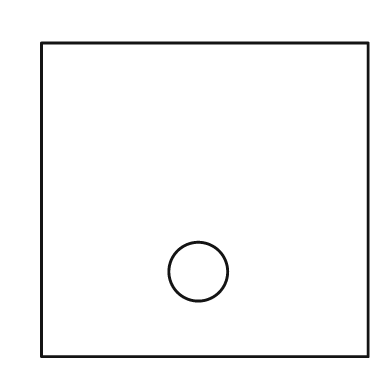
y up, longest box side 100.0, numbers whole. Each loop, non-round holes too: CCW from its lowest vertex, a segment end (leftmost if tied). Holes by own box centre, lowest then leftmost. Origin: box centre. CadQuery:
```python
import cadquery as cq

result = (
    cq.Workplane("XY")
    .moveTo(-50.0, -48.0)
    .lineTo(50.0, -48.0)
    .lineTo(50.0, 48.0)
    .lineTo(-50.0, 48.0)
    .close()
    .moveTo(-2.0, -22.0)
    .circle(9.0)
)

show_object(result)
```